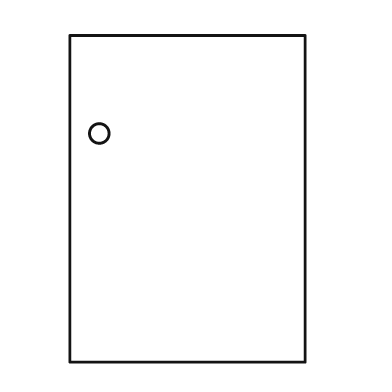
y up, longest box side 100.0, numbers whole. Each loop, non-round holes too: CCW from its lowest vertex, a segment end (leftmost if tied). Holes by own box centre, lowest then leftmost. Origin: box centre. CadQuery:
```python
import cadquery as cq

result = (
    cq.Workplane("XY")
    .moveTo(-36.0, -50.0)
    .lineTo(36.0, -50.0)
    .lineTo(36.0, 50.0)
    .lineTo(-36.0, 50.0)
    .close()
    .moveTo(-27.0, 20.0)
    .circle(3.0)
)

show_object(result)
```